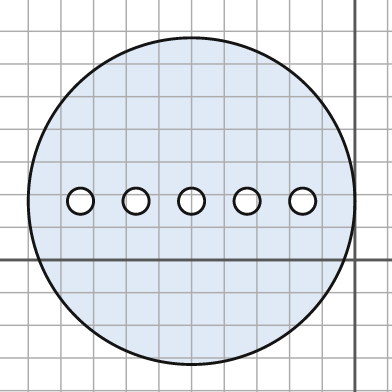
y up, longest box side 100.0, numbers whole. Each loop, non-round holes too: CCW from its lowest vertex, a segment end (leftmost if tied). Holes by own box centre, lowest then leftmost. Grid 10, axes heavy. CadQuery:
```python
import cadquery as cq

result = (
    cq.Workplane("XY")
    .moveTo(-50.0, 18.0)
    .circle(50.0)
    .moveTo(-84.0, 18.0)
    .circle(4.0)
    .moveTo(-67.0, 18.0)
    .circle(4.0)
    .moveTo(-50.0, 18.0)
    .circle(4.0)
    .moveTo(-33.0, 18.0)
    .circle(4.0)
    .moveTo(-16.0, 18.0)
    .circle(4.0)
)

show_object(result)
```